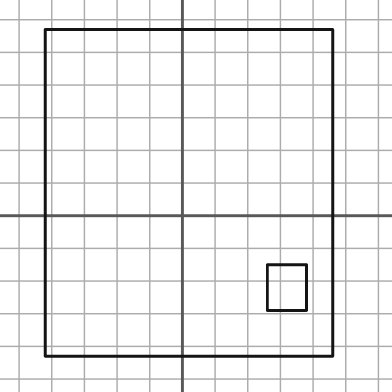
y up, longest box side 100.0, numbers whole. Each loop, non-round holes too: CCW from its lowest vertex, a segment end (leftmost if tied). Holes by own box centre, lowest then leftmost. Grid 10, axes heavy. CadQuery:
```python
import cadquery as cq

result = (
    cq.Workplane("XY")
    .moveTo(-42.0, -43.0)
    .lineTo(46.0, -43.0)
    .lineTo(46.0, 57.0)
    .lineTo(-42.0, 57.0)
    .close()
    .moveTo(26.0, -29.0)
    .lineTo(38.0, -29.0)
    .lineTo(38.0, -15.0)
    .lineTo(26.0, -15.0)
    .close()
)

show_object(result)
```